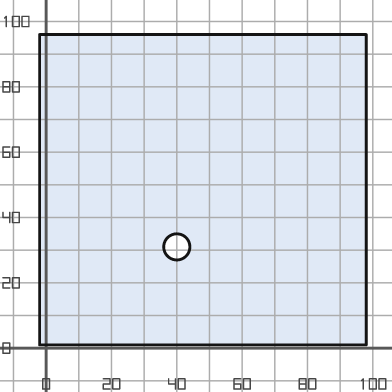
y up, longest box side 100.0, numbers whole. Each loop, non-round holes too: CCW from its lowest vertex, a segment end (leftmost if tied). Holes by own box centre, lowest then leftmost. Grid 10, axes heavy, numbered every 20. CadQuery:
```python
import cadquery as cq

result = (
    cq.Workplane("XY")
    .moveTo(-2.0, 1.0)
    .lineTo(98.0, 1.0)
    .lineTo(98.0, 96.0)
    .lineTo(-2.0, 96.0)
    .close()
    .moveTo(40.0, 31.0)
    .circle(4.0)
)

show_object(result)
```